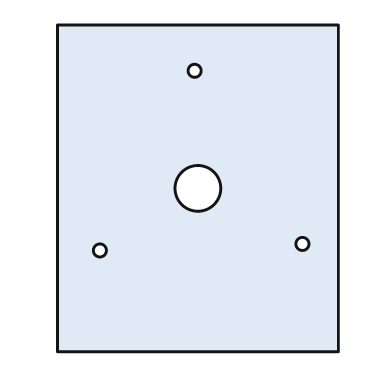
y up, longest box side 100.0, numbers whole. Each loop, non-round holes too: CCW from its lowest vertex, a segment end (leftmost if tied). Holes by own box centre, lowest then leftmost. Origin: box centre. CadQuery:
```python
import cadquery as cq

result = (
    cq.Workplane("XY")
    .moveTo(-43.0, -50.0)
    .lineTo(43.0, -50.0)
    .lineTo(43.0, 50.0)
    .lineTo(-43.0, 50.0)
    .close()
    .moveTo(-30.0, -19.0)
    .circle(2.0)
    .moveTo(32.0, -17.0)
    .circle(2.0)
    .moveTo(0.0, 0.0)
    .circle(7.0)
    .moveTo(-1.0, 36.0)
    .circle(2.0)
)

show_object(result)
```